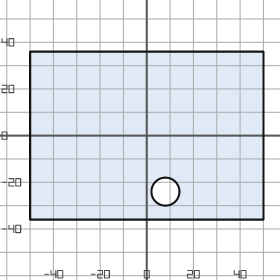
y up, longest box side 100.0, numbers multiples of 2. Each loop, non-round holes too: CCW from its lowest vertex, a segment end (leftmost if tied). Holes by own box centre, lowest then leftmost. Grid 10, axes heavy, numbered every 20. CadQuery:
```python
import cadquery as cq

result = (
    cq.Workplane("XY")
    .moveTo(-50.0, -36.0)
    .lineTo(50.0, -36.0)
    .lineTo(50.0, 36.0)
    .lineTo(-50.0, 36.0)
    .close()
    .moveTo(8.0, -24.0)
    .circle(6.0)
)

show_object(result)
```